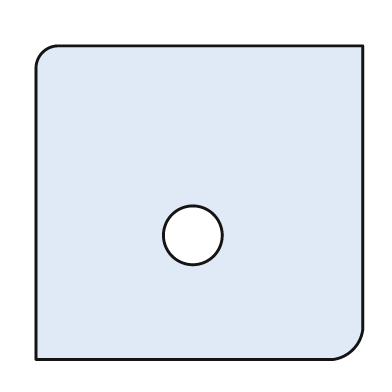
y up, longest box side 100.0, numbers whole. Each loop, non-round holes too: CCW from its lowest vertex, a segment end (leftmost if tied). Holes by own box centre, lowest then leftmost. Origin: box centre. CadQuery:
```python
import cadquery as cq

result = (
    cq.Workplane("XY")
    .moveTo(-50.0, -48.0)
    .lineTo(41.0, -48.0)
    .threePointArc((47.0, -45.0), (50.0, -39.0))
    .lineTo(50.0, 48.0)
    .lineTo(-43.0, 48.0)
    .threePointArc((-48.0, 46.0), (-50.0, 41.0))
    .close()
    .moveTo(-2.0, -10.0)
    .circle(9.0)
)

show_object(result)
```